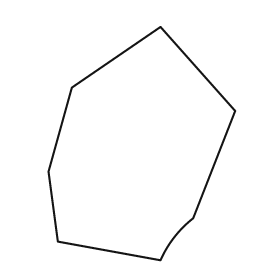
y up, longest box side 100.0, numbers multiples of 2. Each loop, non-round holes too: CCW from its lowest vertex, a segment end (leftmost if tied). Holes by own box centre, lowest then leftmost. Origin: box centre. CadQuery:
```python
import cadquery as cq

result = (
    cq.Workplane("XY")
    .moveTo(8.0, -50.0)
    .threePointArc((14.0, -40.0), (22.0, -32.0))
    .lineTo(40.0, 14.0)
    .lineTo(8.0, 50.0)
    .lineTo(-30.0, 24.0)
    .lineTo(-40.0, -12.0)
    .lineTo(-36.0, -42.0)
    .close()
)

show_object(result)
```